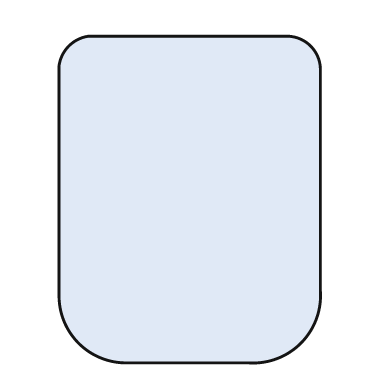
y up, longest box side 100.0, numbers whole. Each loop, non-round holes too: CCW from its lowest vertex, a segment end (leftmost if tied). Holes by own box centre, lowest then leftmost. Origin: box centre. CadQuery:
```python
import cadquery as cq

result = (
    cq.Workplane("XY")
    .moveTo(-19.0, -50.0)
    .lineTo(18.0, -50.0)
    .threePointArc((34.0, -44.0), (40.0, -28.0))
    .lineTo(40.0, 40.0)
    .threePointArc((37.0, 47.0), (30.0, 50.0))
    .lineTo(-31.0, 50.0)
    .threePointArc((-37.0, 47.0), (-40.0, 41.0))
    .lineTo(-40.0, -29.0)
    .threePointArc((-34.0, -44.0), (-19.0, -50.0))
    .close()
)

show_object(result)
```